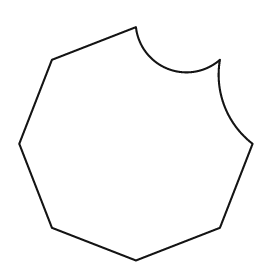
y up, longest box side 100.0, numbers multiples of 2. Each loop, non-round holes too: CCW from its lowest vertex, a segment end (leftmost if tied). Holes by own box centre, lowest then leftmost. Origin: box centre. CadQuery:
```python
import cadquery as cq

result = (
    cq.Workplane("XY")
    .moveTo(0.0, -50.0)
    .lineTo(36.0, -36.0)
    .lineTo(50.0, 0.0)
    .threePointArc((38.0, 16.0), (36.0, 36.0))
    .threePointArc((14.0, 32.0), (0.0, 50.0))
    .lineTo(-36.0, 36.0)
    .lineTo(-50.0, 0.0)
    .lineTo(-36.0, -36.0)
    .close()
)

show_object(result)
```